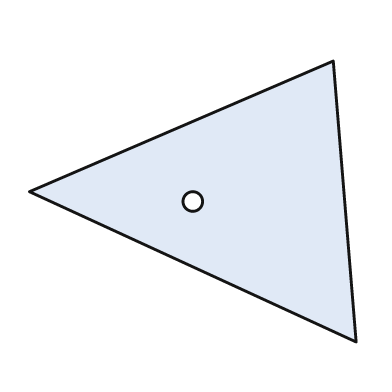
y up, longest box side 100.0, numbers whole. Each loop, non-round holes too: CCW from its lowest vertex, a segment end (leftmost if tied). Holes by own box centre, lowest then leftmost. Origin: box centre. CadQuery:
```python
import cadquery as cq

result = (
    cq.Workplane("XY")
    .moveTo(50.0, -43.0)
    .lineTo(43.0, 43.0)
    .lineTo(-50.0, 3.0)
    .close()
    .moveTo(0.0, 0.0)
    .circle(3.0)
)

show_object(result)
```